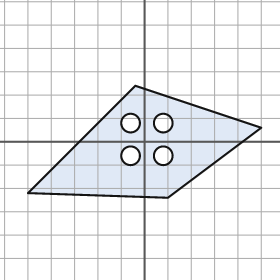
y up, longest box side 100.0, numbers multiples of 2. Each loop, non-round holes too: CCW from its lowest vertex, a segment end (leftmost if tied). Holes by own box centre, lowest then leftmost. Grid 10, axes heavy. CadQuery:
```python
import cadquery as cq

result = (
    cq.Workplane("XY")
    .moveTo(10.0, -24.0)
    .lineTo(50.0, 6.0)
    .lineTo(-4.0, 24.0)
    .lineTo(-50.0, -22.0)
    .close()
    .moveTo(-6.0, -6.0)
    .circle(4.0)
    .moveTo(8.0, -6.0)
    .circle(4.0)
    .moveTo(-6.0, 8.0)
    .circle(4.0)
    .moveTo(8.0, 8.0)
    .circle(4.0)
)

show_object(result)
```